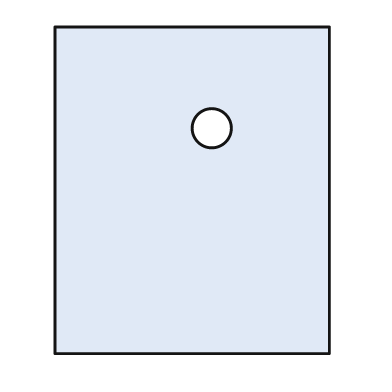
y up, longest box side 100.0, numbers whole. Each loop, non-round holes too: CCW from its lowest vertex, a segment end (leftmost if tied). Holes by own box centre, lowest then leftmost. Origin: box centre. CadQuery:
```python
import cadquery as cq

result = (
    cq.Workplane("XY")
    .moveTo(-42.0, -50.0)
    .lineTo(42.0, -50.0)
    .lineTo(42.0, 50.0)
    .lineTo(-42.0, 50.0)
    .close()
    .moveTo(6.0, 19.0)
    .circle(6.0)
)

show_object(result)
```